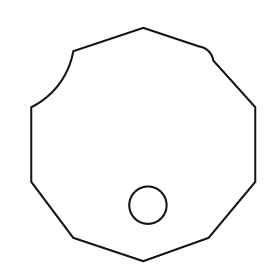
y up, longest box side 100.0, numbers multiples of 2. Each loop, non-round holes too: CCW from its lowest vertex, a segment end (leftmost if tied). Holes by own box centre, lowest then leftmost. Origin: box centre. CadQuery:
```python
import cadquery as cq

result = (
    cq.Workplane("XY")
    .moveTo(0.0, -50.0)
    .lineTo(28.0, -40.0)
    .lineTo(48.0, -16.0)
    .lineTo(48.0, 16.0)
    .lineTo(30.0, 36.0)
    .threePointArc((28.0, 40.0), (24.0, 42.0))
    .lineTo(0.0, 50.0)
    .lineTo(-30.0, 40.0)
    .threePointArc((-36.0, 26.0), (-48.0, 16.0))
    .lineTo(-48.0, -16.0)
    .lineTo(-30.0, -40.0)
    .close()
    .moveTo(2.0, -26.0)
    .circle(8.0)
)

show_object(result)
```